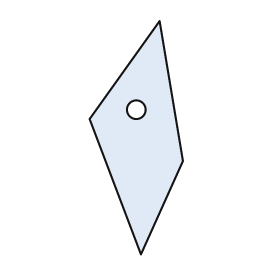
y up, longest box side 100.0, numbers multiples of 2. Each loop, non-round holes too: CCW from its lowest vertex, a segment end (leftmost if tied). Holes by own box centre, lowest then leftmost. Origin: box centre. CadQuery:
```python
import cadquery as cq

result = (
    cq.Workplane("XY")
    .moveTo(2.0, -50.0)
    .lineTo(20.0, -10.0)
    .lineTo(10.0, 50.0)
    .lineTo(-20.0, 8.0)
    .close()
    .moveTo(0.0, 12.0)
    .circle(4.0)
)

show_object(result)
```